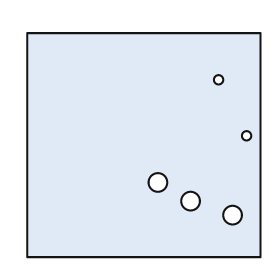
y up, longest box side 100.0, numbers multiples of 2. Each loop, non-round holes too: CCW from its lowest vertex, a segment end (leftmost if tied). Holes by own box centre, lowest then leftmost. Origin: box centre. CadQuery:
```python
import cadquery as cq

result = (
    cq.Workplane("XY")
    .moveTo(-50.0, -48.0)
    .lineTo(50.0, -48.0)
    .lineTo(50.0, 48.0)
    .lineTo(-50.0, 48.0)
    .close()
    .moveTo(38.0, -30.0)
    .circle(4.0)
    .moveTo(20.0, -24.0)
    .circle(4.0)
    .moveTo(6.0, -16.0)
    .circle(4.0)
    .moveTo(44.0, 4.0)
    .circle(2.0)
    .moveTo(32.0, 28.0)
    .circle(2.0)
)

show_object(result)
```